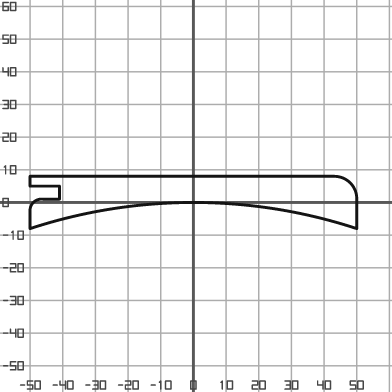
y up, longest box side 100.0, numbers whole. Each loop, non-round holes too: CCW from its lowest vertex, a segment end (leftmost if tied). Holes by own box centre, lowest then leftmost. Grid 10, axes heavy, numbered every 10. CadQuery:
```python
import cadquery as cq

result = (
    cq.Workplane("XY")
    .moveTo(-50.0, -8.0)
    .threePointArc((0.0, 0.0), (50.0, -8.0))
    .lineTo(50.0, 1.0)
    .threePointArc((48.0, 6.0), (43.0, 8.0))
    .lineTo(-50.0, 8.0)
    .lineTo(-50.0, 5.0)
    .lineTo(-41.0, 5.0)
    .lineTo(-41.0, 1.0)
    .lineTo(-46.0, 1.0)
    .threePointArc((-49.0, 0.0), (-50.0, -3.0))
    .close()
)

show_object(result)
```